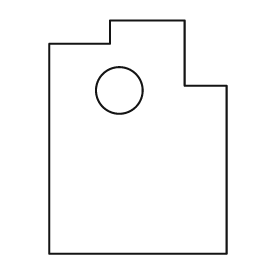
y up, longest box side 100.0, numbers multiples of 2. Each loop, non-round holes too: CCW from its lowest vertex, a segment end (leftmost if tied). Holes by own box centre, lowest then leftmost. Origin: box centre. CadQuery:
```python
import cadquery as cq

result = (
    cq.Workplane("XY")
    .moveTo(-38.0, -50.0)
    .lineTo(38.0, -50.0)
    .lineTo(38.0, 22.0)
    .lineTo(20.0, 22.0)
    .lineTo(20.0, 50.0)
    .lineTo(-12.0, 50.0)
    .lineTo(-12.0, 40.0)
    .lineTo(-38.0, 40.0)
    .close()
    .moveTo(-8.0, 20.0)
    .circle(10.0)
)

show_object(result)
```